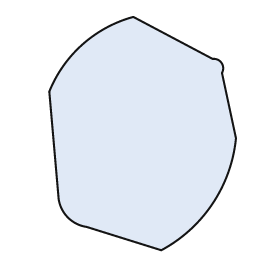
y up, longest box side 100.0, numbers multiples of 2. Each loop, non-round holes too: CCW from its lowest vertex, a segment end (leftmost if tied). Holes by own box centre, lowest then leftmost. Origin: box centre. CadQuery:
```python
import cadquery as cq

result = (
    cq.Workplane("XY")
    .moveTo(8.0, -50.0)
    .threePointArc((30.0, -30.0), (40.0, -2.0))
    .lineTo(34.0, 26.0)
    .threePointArc((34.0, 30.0), (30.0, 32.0))
    .lineTo(-4.0, 50.0)
    .threePointArc((-26.0, 38.0), (-40.0, 18.0))
    .lineTo(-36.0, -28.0)
    .threePointArc((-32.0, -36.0), (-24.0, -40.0))
    .close()
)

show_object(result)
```